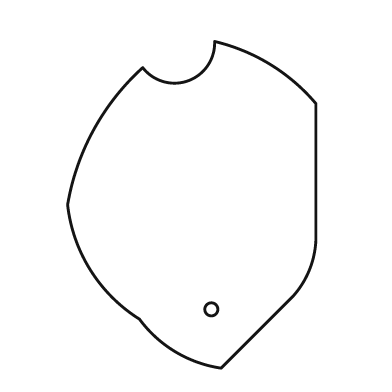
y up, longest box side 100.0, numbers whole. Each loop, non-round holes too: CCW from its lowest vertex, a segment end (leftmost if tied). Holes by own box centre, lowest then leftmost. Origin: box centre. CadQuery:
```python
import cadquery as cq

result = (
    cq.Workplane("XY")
    .moveTo(9.0, -50.0)
    .lineTo(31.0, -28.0)
    .threePointArc((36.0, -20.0), (38.0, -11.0))
    .lineTo(38.0, 31.0)
    .threePointArc((24.0, 43.0), (7.0, 50.0))
    .threePointArc((-1.0, 38.0), (-15.0, 42.0))
    .threePointArc((-30.0, 23.0), (-38.0, 0.0))
    .threePointArc((-31.0, -20.0), (-16.0, -35.0))
    .threePointArc((-5.0, -45.0), (9.0, -50.0))
    .close()
    .moveTo(6.0, -32.0)
    .circle(2.0)
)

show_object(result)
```